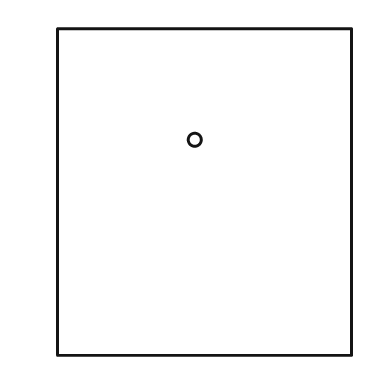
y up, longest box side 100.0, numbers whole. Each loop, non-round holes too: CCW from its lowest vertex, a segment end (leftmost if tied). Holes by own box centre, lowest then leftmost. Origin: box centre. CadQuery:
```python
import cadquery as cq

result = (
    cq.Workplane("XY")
    .moveTo(-45.0, -50.0)
    .lineTo(45.0, -50.0)
    .lineTo(45.0, 50.0)
    .lineTo(-45.0, 50.0)
    .close()
    .moveTo(-3.0, 16.0)
    .circle(2.0)
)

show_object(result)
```